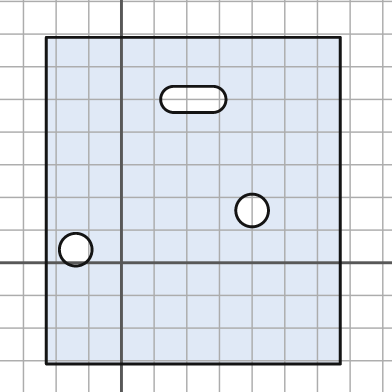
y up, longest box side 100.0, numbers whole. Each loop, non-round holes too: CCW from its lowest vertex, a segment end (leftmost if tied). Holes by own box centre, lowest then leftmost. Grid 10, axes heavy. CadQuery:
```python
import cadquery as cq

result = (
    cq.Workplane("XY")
    .moveTo(-23.0, -31.0)
    .lineTo(67.0, -31.0)
    .lineTo(67.0, 69.0)
    .lineTo(-23.0, 69.0)
    .close()
    .moveTo(-14.0, 4.0)
    .circle(5.0)
    .moveTo(40.0, 16.0)
    .circle(5.0)
    .moveTo(16.0, 46.0)
    .lineTo(28.0, 46.0)
    .threePointArc((32.0, 50.0), (28.0, 54.0))
    .lineTo(16.0, 54.0)
    .threePointArc((12.0, 50.0), (16.0, 46.0))
    .close()
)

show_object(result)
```